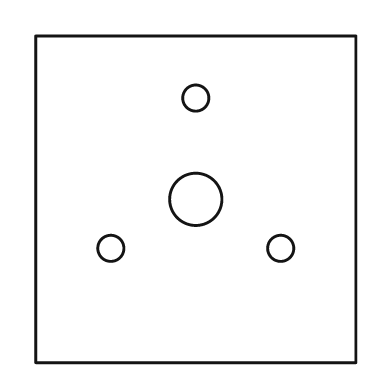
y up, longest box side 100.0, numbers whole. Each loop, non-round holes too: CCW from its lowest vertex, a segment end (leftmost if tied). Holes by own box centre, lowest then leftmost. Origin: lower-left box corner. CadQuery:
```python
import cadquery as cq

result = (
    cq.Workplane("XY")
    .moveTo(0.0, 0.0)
    .lineTo(98.0, 0.0)
    .lineTo(98.0, 100.0)
    .lineTo(0.0, 100.0)
    .close()
    .moveTo(23.0, 35.0)
    .circle(4.0)
    .moveTo(75.0, 35.0)
    .circle(4.0)
    .moveTo(49.0, 50.0)
    .circle(8.0)
    .moveTo(49.0, 81.0)
    .circle(4.0)
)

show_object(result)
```